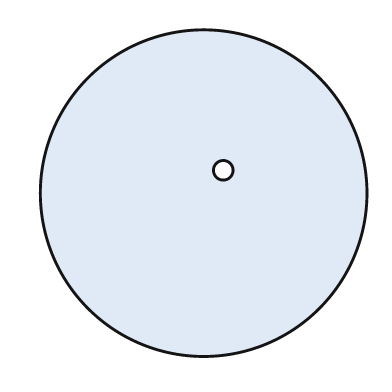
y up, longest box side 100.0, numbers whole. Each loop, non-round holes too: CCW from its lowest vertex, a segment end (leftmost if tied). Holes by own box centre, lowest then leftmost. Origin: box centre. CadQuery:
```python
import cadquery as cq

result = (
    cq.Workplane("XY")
    .moveTo(0.0, 0.0)
    .circle(50.0)
    .moveTo(6.0, 7.0)
    .circle(3.0)
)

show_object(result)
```